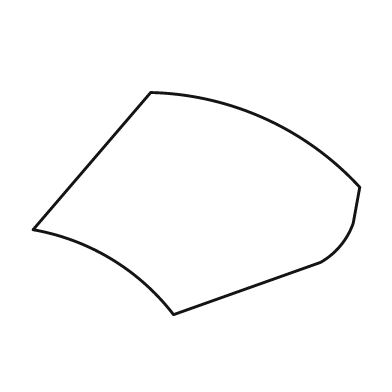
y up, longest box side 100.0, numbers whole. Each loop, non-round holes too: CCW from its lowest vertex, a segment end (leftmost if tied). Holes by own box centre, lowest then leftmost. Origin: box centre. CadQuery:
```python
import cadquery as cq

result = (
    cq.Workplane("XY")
    .moveTo(-7.0, -34.0)
    .lineTo(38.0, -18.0)
    .threePointArc((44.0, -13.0), (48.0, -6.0))
    .lineTo(50.0, 5.0)
    .threePointArc((21.0, 26.0), (-14.0, 34.0))
    .lineTo(-50.0, -8.0)
    .threePointArc((-26.0, -17.0), (-7.0, -34.0))
    .close()
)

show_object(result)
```